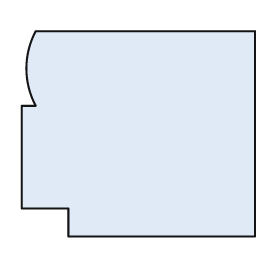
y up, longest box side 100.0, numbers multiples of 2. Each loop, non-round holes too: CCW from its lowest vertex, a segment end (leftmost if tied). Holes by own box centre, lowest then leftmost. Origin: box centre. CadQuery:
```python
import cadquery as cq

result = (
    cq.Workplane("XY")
    .moveTo(-30.0, -44.0)
    .lineTo(50.0, -44.0)
    .lineTo(50.0, 44.0)
    .lineTo(-44.0, 44.0)
    .threePointArc((-48.0, 28.0), (-44.0, 12.0))
    .lineTo(-50.0, 12.0)
    .lineTo(-50.0, -32.0)
    .lineTo(-30.0, -32.0)
    .close()
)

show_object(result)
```